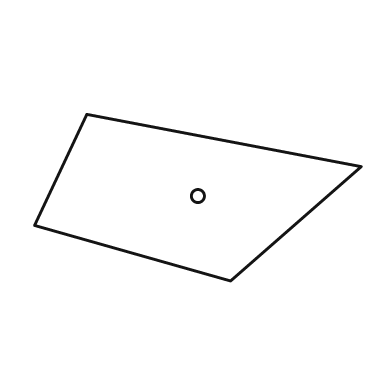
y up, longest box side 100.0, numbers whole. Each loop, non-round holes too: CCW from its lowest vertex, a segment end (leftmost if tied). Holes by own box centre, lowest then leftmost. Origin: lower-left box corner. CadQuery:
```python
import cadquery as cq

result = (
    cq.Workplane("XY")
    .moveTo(60.0, 0.0)
    .lineTo(100.0, 35.0)
    .lineTo(16.0, 51.0)
    .lineTo(0.0, 17.0)
    .close()
    .moveTo(50.0, 26.0)
    .circle(2.0)
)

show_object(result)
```